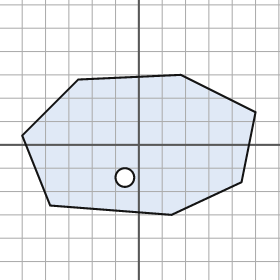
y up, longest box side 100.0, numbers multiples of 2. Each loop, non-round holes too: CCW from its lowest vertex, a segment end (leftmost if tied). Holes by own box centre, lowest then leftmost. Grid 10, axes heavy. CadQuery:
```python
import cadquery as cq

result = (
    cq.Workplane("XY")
    .moveTo(14.0, -30.0)
    .lineTo(44.0, -16.0)
    .lineTo(50.0, 14.0)
    .lineTo(18.0, 30.0)
    .lineTo(-26.0, 28.0)
    .lineTo(-50.0, 4.0)
    .lineTo(-38.0, -26.0)
    .close()
    .moveTo(-6.0, -14.0)
    .circle(4.0)
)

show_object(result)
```